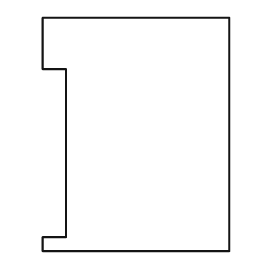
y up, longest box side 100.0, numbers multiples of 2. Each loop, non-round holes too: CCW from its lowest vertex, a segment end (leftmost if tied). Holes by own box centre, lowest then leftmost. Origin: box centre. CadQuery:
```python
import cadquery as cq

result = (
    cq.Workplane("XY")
    .moveTo(-40.0, -50.0)
    .lineTo(40.0, -50.0)
    .lineTo(40.0, 50.0)
    .lineTo(-40.0, 50.0)
    .lineTo(-40.0, 28.0)
    .lineTo(-30.0, 28.0)
    .lineTo(-30.0, -44.0)
    .lineTo(-40.0, -44.0)
    .close()
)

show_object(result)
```